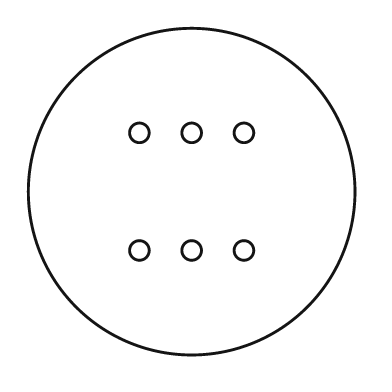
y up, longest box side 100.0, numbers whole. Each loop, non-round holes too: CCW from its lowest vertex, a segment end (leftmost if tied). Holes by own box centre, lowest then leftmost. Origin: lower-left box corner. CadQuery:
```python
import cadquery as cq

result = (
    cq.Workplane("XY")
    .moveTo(50.0, 50.0)
    .circle(50.0)
    .moveTo(34.0, 32.0)
    .circle(3.0)
    .moveTo(50.0, 32.0)
    .circle(3.0)
    .moveTo(66.0, 32.0)
    .circle(3.0)
    .moveTo(34.0, 68.0)
    .circle(3.0)
    .moveTo(50.0, 68.0)
    .circle(3.0)
    .moveTo(66.0, 68.0)
    .circle(3.0)
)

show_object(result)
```